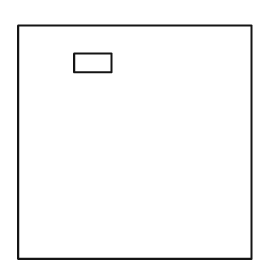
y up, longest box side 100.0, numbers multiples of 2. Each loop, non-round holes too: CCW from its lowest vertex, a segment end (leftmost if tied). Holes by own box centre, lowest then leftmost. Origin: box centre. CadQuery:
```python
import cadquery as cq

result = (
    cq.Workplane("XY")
    .moveTo(-50.0, -50.0)
    .lineTo(50.0, -50.0)
    .lineTo(50.0, 50.0)
    .lineTo(-50.0, 50.0)
    .close()
    .moveTo(-26.0, 30.0)
    .lineTo(-10.0, 30.0)
    .lineTo(-10.0, 38.0)
    .lineTo(-26.0, 38.0)
    .close()
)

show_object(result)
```